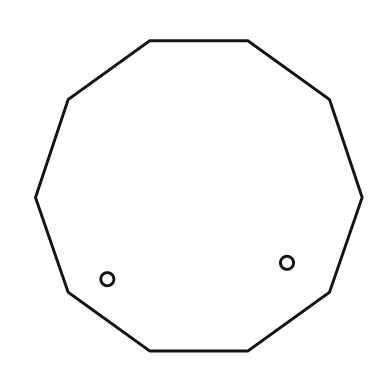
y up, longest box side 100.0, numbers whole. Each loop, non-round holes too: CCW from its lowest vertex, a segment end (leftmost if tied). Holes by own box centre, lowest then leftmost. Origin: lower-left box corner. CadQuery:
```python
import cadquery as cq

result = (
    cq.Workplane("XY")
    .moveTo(35.0, 0.0)
    .lineTo(65.0, 0.0)
    .lineTo(90.0, 18.0)
    .lineTo(100.0, 47.0)
    .lineTo(90.0, 77.0)
    .lineTo(65.0, 95.0)
    .lineTo(35.0, 95.0)
    .lineTo(10.0, 77.0)
    .lineTo(0.0, 47.0)
    .lineTo(10.0, 18.0)
    .close()
    .moveTo(22.0, 22.0)
    .circle(2.0)
    .moveTo(77.0, 27.0)
    .circle(2.0)
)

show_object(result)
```